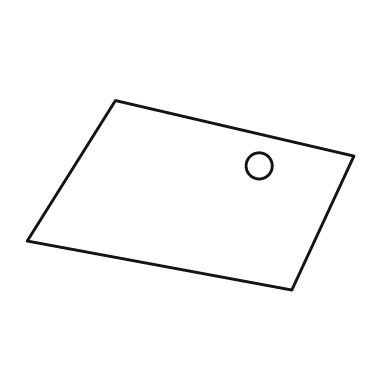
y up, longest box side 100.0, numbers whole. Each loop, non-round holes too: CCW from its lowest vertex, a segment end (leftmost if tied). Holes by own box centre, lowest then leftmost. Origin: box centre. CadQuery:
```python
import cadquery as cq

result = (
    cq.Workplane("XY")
    .moveTo(31.0, -29.0)
    .lineTo(50.0, 12.0)
    .lineTo(-23.0, 29.0)
    .lineTo(-50.0, -14.0)
    .close()
    .moveTo(21.0, 9.0)
    .circle(4.0)
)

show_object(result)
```